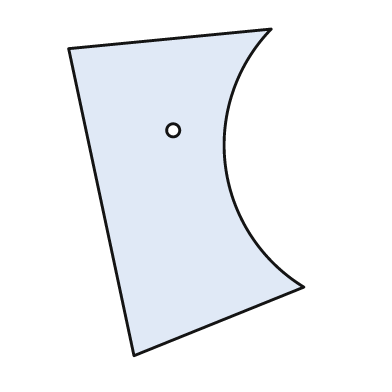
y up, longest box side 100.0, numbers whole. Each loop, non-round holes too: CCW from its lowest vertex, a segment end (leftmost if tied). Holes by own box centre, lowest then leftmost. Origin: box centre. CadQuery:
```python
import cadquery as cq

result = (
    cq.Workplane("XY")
    .moveTo(-16.0, -50.0)
    .lineTo(36.0, -29.0)
    .threePointArc((12.0, 8.0), (26.0, 50.0))
    .lineTo(-36.0, 44.0)
    .close()
    .moveTo(-4.0, 19.0)
    .circle(2.0)
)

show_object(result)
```